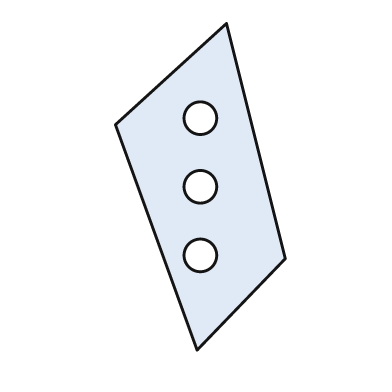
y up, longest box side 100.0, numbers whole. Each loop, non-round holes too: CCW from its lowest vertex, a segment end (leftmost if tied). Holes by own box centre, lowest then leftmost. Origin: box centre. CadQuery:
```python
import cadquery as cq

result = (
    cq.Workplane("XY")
    .moveTo(-1.0, -50.0)
    .lineTo(26.0, -22.0)
    .lineTo(8.0, 50.0)
    .lineTo(-26.0, 19.0)
    .close()
    .moveTo(0.0, -21.0)
    .circle(5.0)
    .moveTo(0.0, 0.0)
    .circle(5.0)
    .moveTo(0.0, 21.0)
    .circle(5.0)
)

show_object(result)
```